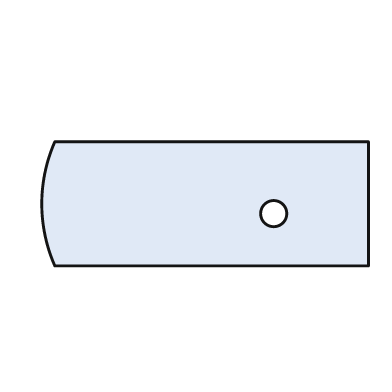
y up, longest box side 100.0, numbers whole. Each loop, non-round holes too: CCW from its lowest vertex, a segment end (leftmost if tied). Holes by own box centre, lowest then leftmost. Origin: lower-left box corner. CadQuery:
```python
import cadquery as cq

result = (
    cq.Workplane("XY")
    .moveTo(4.0, 0.0)
    .lineTo(100.0, 0.0)
    .lineTo(100.0, 38.0)
    .lineTo(4.0, 38.0)
    .threePointArc((0.0, 19.0), (4.0, 0.0))
    .close()
    .moveTo(71.0, 16.0)
    .circle(4.0)
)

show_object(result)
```